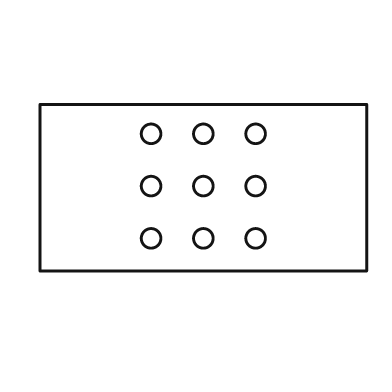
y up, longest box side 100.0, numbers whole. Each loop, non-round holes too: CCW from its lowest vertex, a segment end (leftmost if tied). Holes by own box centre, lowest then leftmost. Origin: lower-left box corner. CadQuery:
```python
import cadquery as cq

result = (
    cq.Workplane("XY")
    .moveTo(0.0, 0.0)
    .lineTo(100.0, 0.0)
    .lineTo(100.0, 51.0)
    .lineTo(0.0, 51.0)
    .close()
    .moveTo(34.0, 10.0)
    .circle(3.0)
    .moveTo(50.0, 10.0)
    .circle(3.0)
    .moveTo(66.0, 10.0)
    .circle(3.0)
    .moveTo(34.0, 26.0)
    .circle(3.0)
    .moveTo(50.0, 26.0)
    .circle(3.0)
    .moveTo(66.0, 26.0)
    .circle(3.0)
    .moveTo(34.0, 42.0)
    .circle(3.0)
    .moveTo(50.0, 42.0)
    .circle(3.0)
    .moveTo(66.0, 42.0)
    .circle(3.0)
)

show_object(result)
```